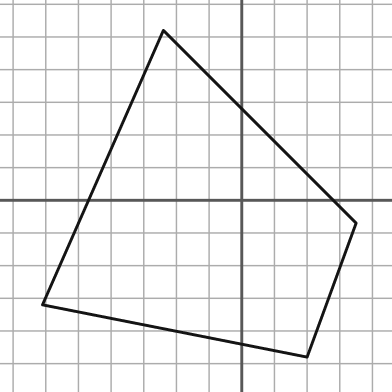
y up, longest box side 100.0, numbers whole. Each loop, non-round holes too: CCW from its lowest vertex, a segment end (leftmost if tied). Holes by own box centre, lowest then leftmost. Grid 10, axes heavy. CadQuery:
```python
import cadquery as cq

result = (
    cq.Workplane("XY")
    .moveTo(20.0, -48.0)
    .lineTo(35.0, -7.0)
    .lineTo(-24.0, 52.0)
    .lineTo(-61.0, -32.0)
    .close()
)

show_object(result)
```